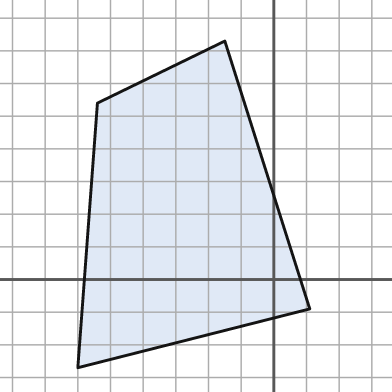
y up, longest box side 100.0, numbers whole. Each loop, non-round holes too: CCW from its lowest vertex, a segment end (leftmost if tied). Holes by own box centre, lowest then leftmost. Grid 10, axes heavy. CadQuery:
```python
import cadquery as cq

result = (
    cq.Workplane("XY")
    .moveTo(-60.0, -27.0)
    .lineTo(11.0, -9.0)
    .lineTo(-15.0, 73.0)
    .lineTo(-54.0, 54.0)
    .close()
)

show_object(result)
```